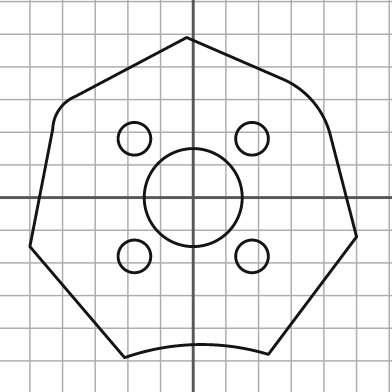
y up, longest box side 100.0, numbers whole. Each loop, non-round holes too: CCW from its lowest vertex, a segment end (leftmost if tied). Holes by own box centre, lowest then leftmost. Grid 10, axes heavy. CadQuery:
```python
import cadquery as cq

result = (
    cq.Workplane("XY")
    .moveTo(-21.0, -49.0)
    .threePointArc((1.0, -45.0), (23.0, -48.0))
    .lineTo(50.0, -12.0)
    .lineTo(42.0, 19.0)
    .threePointArc((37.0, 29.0), (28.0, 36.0))
    .lineTo(-2.0, 49.0)
    .lineTo(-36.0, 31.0)
    .threePointArc((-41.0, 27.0), (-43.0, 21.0))
    .lineTo(-50.0, -15.0)
    .close()
    .moveTo(-18.0, -18.0)
    .circle(5.0)
    .moveTo(18.0, -18.0)
    .circle(5.0)
    .moveTo(0.0, 0.0)
    .circle(15.0)
    .moveTo(-18.0, 18.0)
    .circle(5.0)
    .moveTo(18.0, 18.0)
    .circle(5.0)
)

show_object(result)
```